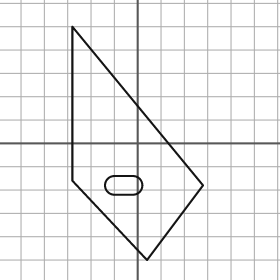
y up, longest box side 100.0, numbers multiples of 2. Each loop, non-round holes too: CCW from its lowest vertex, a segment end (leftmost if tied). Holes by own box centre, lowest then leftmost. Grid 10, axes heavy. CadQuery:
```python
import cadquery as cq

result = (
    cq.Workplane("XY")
    .moveTo(4.0, -50.0)
    .lineTo(28.0, -18.0)
    .lineTo(-28.0, 50.0)
    .lineTo(-28.0, -16.0)
    .close()
    .moveTo(-10.0, -22.0)
    .lineTo(-2.0, -22.0)
    .threePointArc((2.0, -18.0), (-2.0, -14.0))
    .lineTo(-10.0, -14.0)
    .threePointArc((-14.0, -18.0), (-10.0, -22.0))
    .close()
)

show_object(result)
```